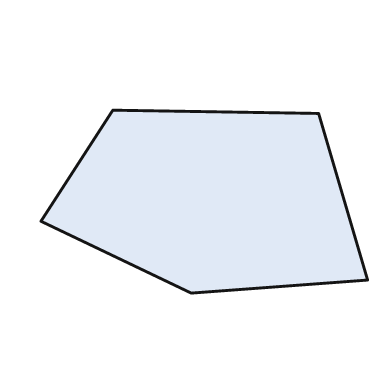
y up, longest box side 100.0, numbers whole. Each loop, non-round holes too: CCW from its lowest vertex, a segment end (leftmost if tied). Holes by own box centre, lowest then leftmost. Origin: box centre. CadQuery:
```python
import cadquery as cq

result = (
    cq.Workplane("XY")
    .moveTo(-4.0, -28.0)
    .lineTo(50.0, -24.0)
    .lineTo(35.0, 27.0)
    .lineTo(-28.0, 28.0)
    .lineTo(-50.0, -6.0)
    .close()
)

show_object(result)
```